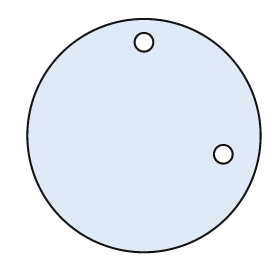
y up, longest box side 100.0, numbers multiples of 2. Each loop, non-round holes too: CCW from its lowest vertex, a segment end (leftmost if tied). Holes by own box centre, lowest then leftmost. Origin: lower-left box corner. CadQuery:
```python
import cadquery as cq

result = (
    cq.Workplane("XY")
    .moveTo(50.0, 50.0)
    .circle(50.0)
    .moveTo(84.0, 42.0)
    .circle(4.0)
    .moveTo(50.0, 90.0)
    .circle(4.0)
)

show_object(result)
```